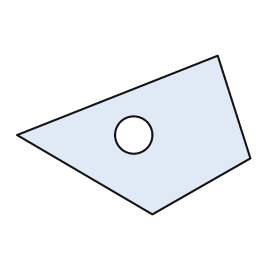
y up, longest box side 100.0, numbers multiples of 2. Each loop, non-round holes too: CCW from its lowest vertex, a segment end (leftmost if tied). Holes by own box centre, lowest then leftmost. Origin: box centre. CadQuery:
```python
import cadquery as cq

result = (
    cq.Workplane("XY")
    .moveTo(8.0, -34.0)
    .lineTo(50.0, -10.0)
    .lineTo(36.0, 34.0)
    .lineTo(-50.0, 0.0)
    .close()
    .moveTo(0.0, 0.0)
    .circle(8.0)
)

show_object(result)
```